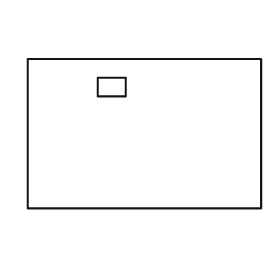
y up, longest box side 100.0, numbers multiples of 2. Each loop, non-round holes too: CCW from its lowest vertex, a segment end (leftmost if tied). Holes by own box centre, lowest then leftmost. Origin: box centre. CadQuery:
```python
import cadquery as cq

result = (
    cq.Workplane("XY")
    .moveTo(-50.0, -32.0)
    .lineTo(50.0, -32.0)
    .lineTo(50.0, 32.0)
    .lineTo(-50.0, 32.0)
    .close()
    .moveTo(-20.0, 16.0)
    .lineTo(-8.0, 16.0)
    .lineTo(-8.0, 24.0)
    .lineTo(-20.0, 24.0)
    .close()
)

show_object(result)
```